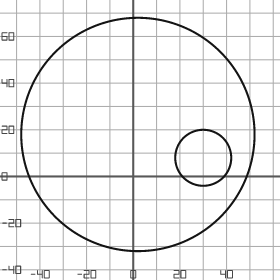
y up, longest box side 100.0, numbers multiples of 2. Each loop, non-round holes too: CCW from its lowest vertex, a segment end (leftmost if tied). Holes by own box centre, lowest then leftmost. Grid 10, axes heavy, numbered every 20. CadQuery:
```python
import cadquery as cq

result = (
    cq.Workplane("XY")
    .moveTo(2.0, 18.0)
    .circle(50.0)
    .moveTo(30.0, 8.0)
    .circle(12.0)
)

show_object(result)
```